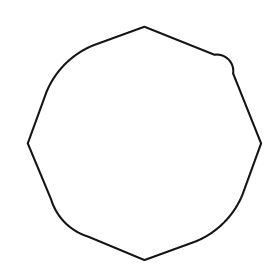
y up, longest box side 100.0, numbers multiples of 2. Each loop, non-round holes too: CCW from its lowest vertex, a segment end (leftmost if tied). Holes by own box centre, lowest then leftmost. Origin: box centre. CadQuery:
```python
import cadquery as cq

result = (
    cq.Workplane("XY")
    .moveTo(0.0, -50.0)
    .lineTo(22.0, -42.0)
    .threePointArc((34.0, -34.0), (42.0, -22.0))
    .lineTo(50.0, 0.0)
    .lineTo(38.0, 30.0)
    .threePointArc((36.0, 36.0), (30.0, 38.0))
    .lineTo(0.0, 50.0)
    .lineTo(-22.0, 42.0)
    .threePointArc((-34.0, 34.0), (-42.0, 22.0))
    .lineTo(-50.0, 0.0)
    .lineTo(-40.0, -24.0)
    .threePointArc((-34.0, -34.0), (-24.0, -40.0))
    .close()
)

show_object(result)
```